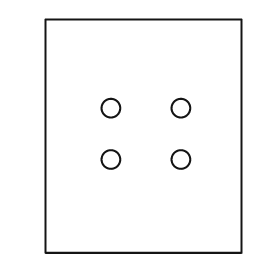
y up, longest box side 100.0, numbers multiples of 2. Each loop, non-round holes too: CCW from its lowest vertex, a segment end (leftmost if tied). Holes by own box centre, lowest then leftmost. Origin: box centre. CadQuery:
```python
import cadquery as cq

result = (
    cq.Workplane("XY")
    .moveTo(-42.0, -50.0)
    .lineTo(42.0, -50.0)
    .lineTo(42.0, 50.0)
    .lineTo(-42.0, 50.0)
    .close()
    .moveTo(-14.0, -10.0)
    .circle(4.0)
    .moveTo(16.0, -10.0)
    .circle(4.0)
    .moveTo(-14.0, 12.0)
    .circle(4.0)
    .moveTo(16.0, 12.0)
    .circle(4.0)
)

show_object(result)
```